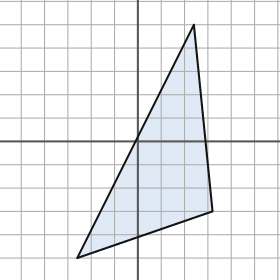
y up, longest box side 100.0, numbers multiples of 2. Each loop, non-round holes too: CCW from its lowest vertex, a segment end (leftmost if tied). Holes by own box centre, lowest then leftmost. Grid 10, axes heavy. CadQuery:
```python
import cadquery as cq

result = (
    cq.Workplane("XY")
    .moveTo(-26.0, -50.0)
    .lineTo(32.0, -30.0)
    .lineTo(24.0, 50.0)
    .close()
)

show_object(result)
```